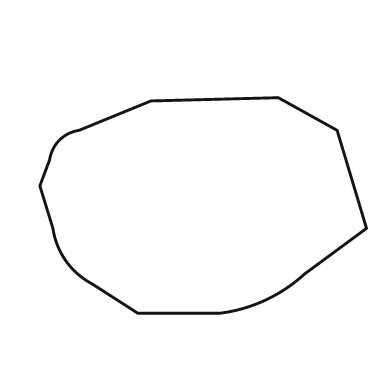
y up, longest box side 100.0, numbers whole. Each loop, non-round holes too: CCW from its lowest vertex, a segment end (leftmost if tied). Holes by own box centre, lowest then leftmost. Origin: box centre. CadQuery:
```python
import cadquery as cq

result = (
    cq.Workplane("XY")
    .moveTo(-20.0, -33.0)
    .lineTo(5.0, -33.0)
    .threePointArc((19.0, -29.0), (31.0, -21.0))
    .lineTo(50.0, -7.0)
    .lineTo(41.0, 23.0)
    .lineTo(23.0, 33.0)
    .lineTo(-16.0, 32.0)
    .lineTo(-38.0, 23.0)
    .threePointArc((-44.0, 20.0), (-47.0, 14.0))
    .lineTo(-50.0, 6.0)
    .lineTo(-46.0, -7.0)
    .threePointArc((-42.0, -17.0), (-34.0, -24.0))
    .close()
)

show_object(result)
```